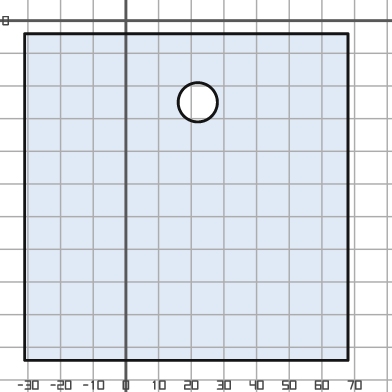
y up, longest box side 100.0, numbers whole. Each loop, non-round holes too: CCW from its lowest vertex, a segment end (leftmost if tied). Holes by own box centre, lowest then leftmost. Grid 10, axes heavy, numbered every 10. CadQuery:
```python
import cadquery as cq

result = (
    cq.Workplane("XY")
    .moveTo(-31.0, -104.0)
    .lineTo(68.0, -104.0)
    .lineTo(68.0, -4.0)
    .lineTo(-31.0, -4.0)
    .close()
    .moveTo(22.0, -25.0)
    .circle(6.0)
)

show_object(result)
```